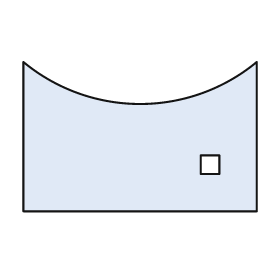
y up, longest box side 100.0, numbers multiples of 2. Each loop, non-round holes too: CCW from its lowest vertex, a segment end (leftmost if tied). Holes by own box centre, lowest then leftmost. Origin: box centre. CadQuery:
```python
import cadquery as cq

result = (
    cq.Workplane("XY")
    .moveTo(-50.0, -32.0)
    .lineTo(50.0, -32.0)
    .lineTo(50.0, 32.0)
    .threePointArc((0.0, 14.0), (-50.0, 32.0))
    .close()
    .moveTo(26.0, -16.0)
    .lineTo(34.0, -16.0)
    .lineTo(34.0, -8.0)
    .lineTo(26.0, -8.0)
    .close()
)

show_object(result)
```